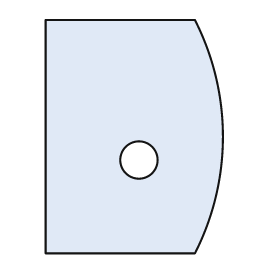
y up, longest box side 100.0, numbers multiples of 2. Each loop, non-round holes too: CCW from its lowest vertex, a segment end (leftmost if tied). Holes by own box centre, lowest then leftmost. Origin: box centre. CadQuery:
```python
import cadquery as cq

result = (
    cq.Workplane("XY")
    .moveTo(-38.0, -50.0)
    .lineTo(26.0, -50.0)
    .threePointArc((38.0, 0.0), (26.0, 50.0))
    .lineTo(-38.0, 50.0)
    .close()
    .moveTo(2.0, -10.0)
    .circle(8.0)
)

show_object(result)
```